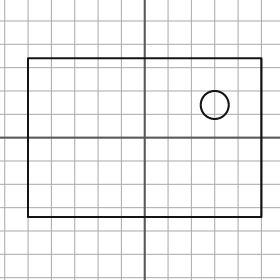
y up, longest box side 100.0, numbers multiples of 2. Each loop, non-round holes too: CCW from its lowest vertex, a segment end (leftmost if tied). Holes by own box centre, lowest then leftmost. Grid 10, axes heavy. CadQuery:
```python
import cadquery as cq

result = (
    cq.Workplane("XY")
    .moveTo(-50.0, -34.0)
    .lineTo(50.0, -34.0)
    .lineTo(50.0, 34.0)
    .lineTo(-50.0, 34.0)
    .close()
    .moveTo(30.0, 14.0)
    .circle(6.0)
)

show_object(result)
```